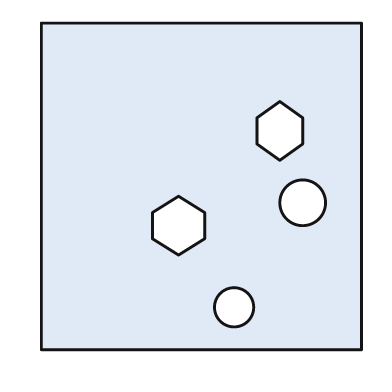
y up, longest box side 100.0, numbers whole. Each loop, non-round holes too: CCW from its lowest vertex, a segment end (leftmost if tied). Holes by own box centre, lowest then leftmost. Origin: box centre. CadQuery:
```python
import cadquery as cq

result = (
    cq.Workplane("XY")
    .moveTo(-49.0, -50.0)
    .lineTo(49.0, -50.0)
    .lineTo(49.0, 50.0)
    .lineTo(-49.0, 50.0)
    .close()
    .moveTo(10.0, -37.0)
    .circle(6.0)
    .moveTo(-7.0, -21.0)
    .lineTo(1.0, -16.0)
    .lineTo(1.0, -8.0)
    .lineTo(-7.0, -3.0)
    .lineTo(-15.0, -8.0)
    .lineTo(-15.0, -16.0)
    .close()
    .moveTo(31.0, -5.0)
    .circle(7.0)
    .moveTo(24.0, 8.0)
    .lineTo(31.0, 13.0)
    .lineTo(31.0, 21.0)
    .lineTo(24.0, 26.0)
    .lineTo(17.0, 21.0)
    .lineTo(17.0, 13.0)
    .close()
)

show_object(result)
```